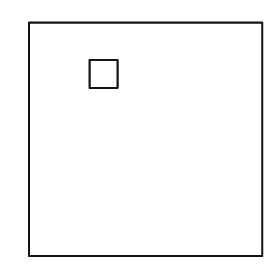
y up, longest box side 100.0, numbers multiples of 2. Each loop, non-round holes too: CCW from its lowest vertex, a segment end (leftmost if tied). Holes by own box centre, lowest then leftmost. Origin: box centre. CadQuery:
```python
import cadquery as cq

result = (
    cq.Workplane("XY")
    .moveTo(-50.0, -50.0)
    .lineTo(50.0, -50.0)
    .lineTo(50.0, 50.0)
    .lineTo(-50.0, 50.0)
    .close()
    .moveTo(-24.0, 22.0)
    .lineTo(-12.0, 22.0)
    .lineTo(-12.0, 34.0)
    .lineTo(-24.0, 34.0)
    .close()
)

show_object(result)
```